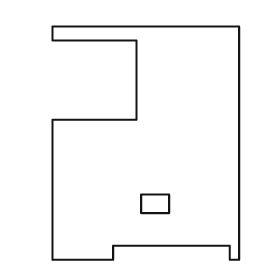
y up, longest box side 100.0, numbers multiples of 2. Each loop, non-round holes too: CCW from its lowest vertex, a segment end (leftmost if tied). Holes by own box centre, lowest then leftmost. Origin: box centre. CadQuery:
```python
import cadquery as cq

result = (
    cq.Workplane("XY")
    .moveTo(-40.0, -50.0)
    .lineTo(-14.0, -50.0)
    .lineTo(-14.0, -44.0)
    .lineTo(36.0, -44.0)
    .lineTo(36.0, -50.0)
    .lineTo(40.0, -50.0)
    .lineTo(40.0, 50.0)
    .lineTo(-40.0, 50.0)
    .lineTo(-40.0, 44.0)
    .lineTo(-4.0, 44.0)
    .lineTo(-4.0, 10.0)
    .lineTo(-40.0, 10.0)
    .close()
    .moveTo(-2.0, -30.0)
    .lineTo(10.0, -30.0)
    .lineTo(10.0, -22.0)
    .lineTo(-2.0, -22.0)
    .close()
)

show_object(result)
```